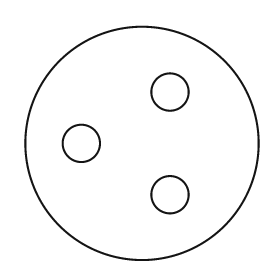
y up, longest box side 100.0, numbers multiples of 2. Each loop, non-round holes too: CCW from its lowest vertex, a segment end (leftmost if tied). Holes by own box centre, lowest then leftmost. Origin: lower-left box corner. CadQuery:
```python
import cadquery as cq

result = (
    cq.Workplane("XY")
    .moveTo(50.0, 50.0)
    .circle(50.0)
    .moveTo(62.0, 28.0)
    .circle(8.0)
    .moveTo(24.0, 50.0)
    .circle(8.0)
    .moveTo(62.0, 72.0)
    .circle(8.0)
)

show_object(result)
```